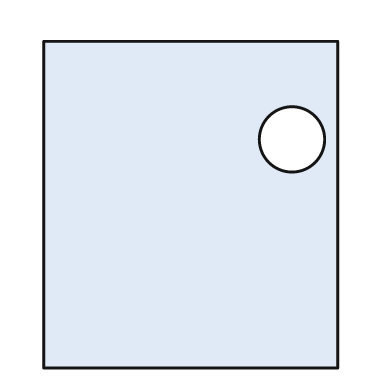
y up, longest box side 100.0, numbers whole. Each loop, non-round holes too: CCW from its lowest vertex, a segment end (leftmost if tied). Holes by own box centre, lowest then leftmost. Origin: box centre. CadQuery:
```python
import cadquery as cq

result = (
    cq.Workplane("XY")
    .moveTo(-45.0, -50.0)
    .lineTo(45.0, -50.0)
    .lineTo(45.0, 50.0)
    .lineTo(-45.0, 50.0)
    .close()
    .moveTo(31.0, 20.0)
    .circle(10.0)
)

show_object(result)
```